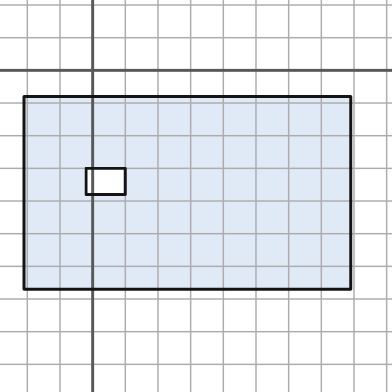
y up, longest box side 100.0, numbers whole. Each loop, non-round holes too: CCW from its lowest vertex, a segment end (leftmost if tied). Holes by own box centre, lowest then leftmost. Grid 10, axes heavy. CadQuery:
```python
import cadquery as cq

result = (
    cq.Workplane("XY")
    .moveTo(-21.0, -67.0)
    .lineTo(79.0, -67.0)
    .lineTo(79.0, -8.0)
    .lineTo(-21.0, -8.0)
    .close()
    .moveTo(-2.0, -38.0)
    .lineTo(10.0, -38.0)
    .lineTo(10.0, -30.0)
    .lineTo(-2.0, -30.0)
    .close()
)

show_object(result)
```